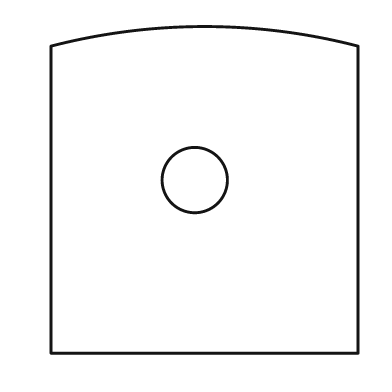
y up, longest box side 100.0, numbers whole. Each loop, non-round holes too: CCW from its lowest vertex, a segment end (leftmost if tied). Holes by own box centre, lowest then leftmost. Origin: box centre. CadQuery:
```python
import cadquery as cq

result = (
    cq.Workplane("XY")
    .moveTo(-47.0, -50.0)
    .lineTo(47.0, -50.0)
    .lineTo(47.0, 44.0)
    .threePointArc((0.0, 50.0), (-47.0, 44.0))
    .close()
    .moveTo(-3.0, 3.0)
    .circle(10.0)
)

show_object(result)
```